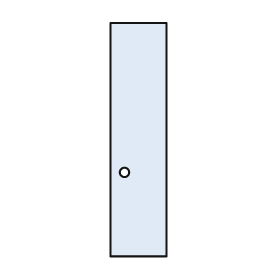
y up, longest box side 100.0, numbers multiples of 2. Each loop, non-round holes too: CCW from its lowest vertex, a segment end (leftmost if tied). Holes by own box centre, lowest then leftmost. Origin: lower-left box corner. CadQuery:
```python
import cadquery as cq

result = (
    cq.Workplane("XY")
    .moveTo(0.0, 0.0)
    .lineTo(24.0, 0.0)
    .lineTo(24.0, 100.0)
    .lineTo(0.0, 100.0)
    .close()
    .moveTo(6.0, 36.0)
    .circle(2.0)
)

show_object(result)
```